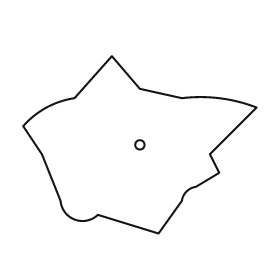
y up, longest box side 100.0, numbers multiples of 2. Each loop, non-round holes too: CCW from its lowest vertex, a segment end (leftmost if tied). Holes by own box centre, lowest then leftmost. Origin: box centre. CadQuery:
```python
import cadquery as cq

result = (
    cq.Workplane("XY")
    .moveTo(8.0, -38.0)
    .lineTo(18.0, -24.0)
    .threePointArc((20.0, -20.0), (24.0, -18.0))
    .lineTo(34.0, -12.0)
    .lineTo(30.0, -4.0)
    .lineTo(50.0, 16.0)
    .threePointArc((34.0, 20.0), (18.0, 20.0))
    .lineTo(0.0, 24.0)
    .lineTo(-12.0, 38.0)
    .lineTo(-28.0, 20.0)
    .threePointArc((-40.0, 16.0), (-50.0, 8.0))
    .lineTo(-42.0, -4.0)
    .lineTo(-34.0, -24.0)
    .threePointArc((-28.0, -32.0), (-18.0, -30.0))
    .close()
    .moveTo(0.0, 0.0)
    .circle(2.0)
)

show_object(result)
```